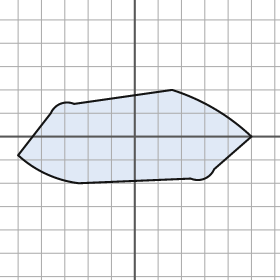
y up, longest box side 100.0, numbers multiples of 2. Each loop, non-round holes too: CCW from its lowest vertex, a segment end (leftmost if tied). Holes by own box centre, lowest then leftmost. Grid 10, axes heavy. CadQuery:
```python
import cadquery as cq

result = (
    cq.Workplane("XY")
    .moveTo(-24.0, -20.0)
    .lineTo(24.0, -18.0)
    .threePointArc((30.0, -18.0), (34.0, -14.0))
    .lineTo(50.0, 0.0)
    .threePointArc((34.0, 12.0), (16.0, 20.0))
    .lineTo(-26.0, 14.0)
    .threePointArc((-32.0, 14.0), (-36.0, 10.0))
    .lineTo(-50.0, -8.0)
    .threePointArc((-38.0, -16.0), (-24.0, -20.0))
    .close()
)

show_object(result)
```